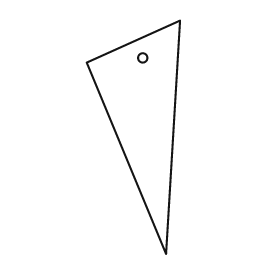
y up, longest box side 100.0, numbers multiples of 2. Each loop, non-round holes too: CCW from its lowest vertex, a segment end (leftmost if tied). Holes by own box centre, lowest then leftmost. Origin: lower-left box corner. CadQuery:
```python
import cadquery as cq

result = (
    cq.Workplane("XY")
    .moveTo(34.0, 0.0)
    .lineTo(40.0, 100.0)
    .lineTo(0.0, 82.0)
    .close()
    .moveTo(24.0, 84.0)
    .circle(2.0)
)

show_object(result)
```